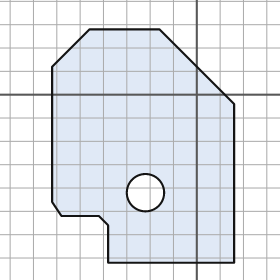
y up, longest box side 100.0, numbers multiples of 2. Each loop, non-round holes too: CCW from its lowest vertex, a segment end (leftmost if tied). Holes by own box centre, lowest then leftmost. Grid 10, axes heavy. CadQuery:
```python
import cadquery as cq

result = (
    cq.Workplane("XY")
    .moveTo(-38.0, -72.0)
    .lineTo(16.0, -72.0)
    .lineTo(16.0, -4.0)
    .lineTo(-16.0, 28.0)
    .lineTo(-46.0, 28.0)
    .lineTo(-62.0, 12.0)
    .lineTo(-62.0, -46.0)
    .lineTo(-58.0, -52.0)
    .lineTo(-42.0, -52.0)
    .lineTo(-38.0, -56.0)
    .close()
    .moveTo(-22.0, -42.0)
    .circle(8.0)
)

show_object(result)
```